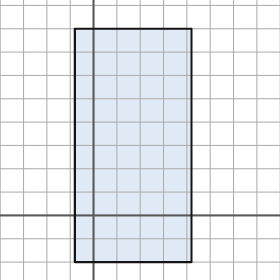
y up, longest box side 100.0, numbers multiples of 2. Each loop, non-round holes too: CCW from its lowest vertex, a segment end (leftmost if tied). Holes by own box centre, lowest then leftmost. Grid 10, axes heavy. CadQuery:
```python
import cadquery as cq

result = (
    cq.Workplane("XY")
    .moveTo(-8.0, -20.0)
    .lineTo(42.0, -20.0)
    .lineTo(42.0, 80.0)
    .lineTo(-8.0, 80.0)
    .close()
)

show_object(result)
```